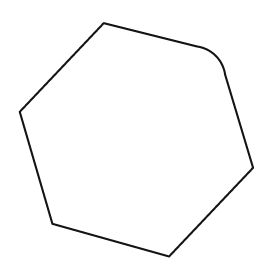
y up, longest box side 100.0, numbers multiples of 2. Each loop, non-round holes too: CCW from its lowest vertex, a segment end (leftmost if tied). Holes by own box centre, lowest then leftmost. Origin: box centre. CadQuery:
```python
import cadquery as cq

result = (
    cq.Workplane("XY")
    .moveTo(14.0, -50.0)
    .lineTo(50.0, -12.0)
    .lineTo(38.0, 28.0)
    .threePointArc((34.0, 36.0), (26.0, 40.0))
    .lineTo(-14.0, 50.0)
    .lineTo(-50.0, 12.0)
    .lineTo(-36.0, -36.0)
    .close()
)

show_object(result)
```